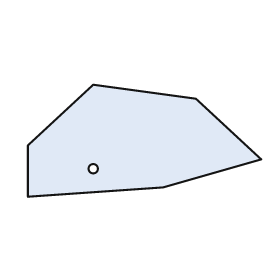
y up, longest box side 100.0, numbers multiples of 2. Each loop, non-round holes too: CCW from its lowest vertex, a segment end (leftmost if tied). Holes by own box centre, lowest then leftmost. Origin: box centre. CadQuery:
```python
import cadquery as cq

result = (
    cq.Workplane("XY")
    .moveTo(-50.0, -24.0)
    .lineTo(8.0, -20.0)
    .lineTo(50.0, -8.0)
    .lineTo(22.0, 18.0)
    .lineTo(-22.0, 24.0)
    .lineTo(-50.0, -2.0)
    .close()
    .moveTo(-22.0, -12.0)
    .circle(2.0)
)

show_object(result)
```